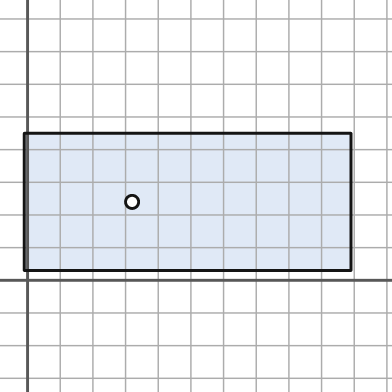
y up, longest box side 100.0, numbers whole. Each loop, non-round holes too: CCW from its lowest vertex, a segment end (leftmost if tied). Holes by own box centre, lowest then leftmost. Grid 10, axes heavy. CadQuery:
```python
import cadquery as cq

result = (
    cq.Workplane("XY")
    .moveTo(-1.0, 3.0)
    .lineTo(99.0, 3.0)
    .lineTo(99.0, 45.0)
    .lineTo(-1.0, 45.0)
    .close()
    .moveTo(32.0, 24.0)
    .circle(2.0)
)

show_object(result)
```